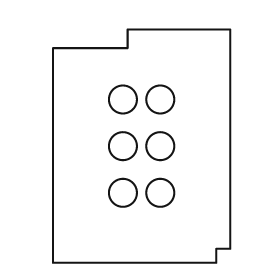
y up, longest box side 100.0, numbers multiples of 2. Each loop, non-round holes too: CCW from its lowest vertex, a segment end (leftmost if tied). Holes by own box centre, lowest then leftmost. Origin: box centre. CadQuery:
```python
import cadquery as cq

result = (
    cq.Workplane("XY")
    .moveTo(-38.0, -50.0)
    .lineTo(32.0, -50.0)
    .lineTo(32.0, -44.0)
    .lineTo(38.0, -44.0)
    .lineTo(38.0, 50.0)
    .lineTo(-6.0, 50.0)
    .lineTo(-6.0, 42.0)
    .lineTo(-38.0, 42.0)
    .close()
    .moveTo(-8.0, -20.0)
    .circle(6.0)
    .moveTo(8.0, -20.0)
    .circle(6.0)
    .moveTo(-8.0, 0.0)
    .circle(6.0)
    .moveTo(8.0, 0.0)
    .circle(6.0)
    .moveTo(-8.0, 20.0)
    .circle(6.0)
    .moveTo(8.0, 20.0)
    .circle(6.0)
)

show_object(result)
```